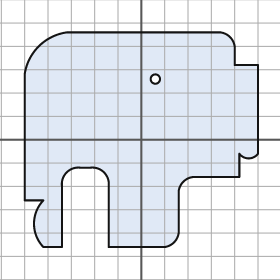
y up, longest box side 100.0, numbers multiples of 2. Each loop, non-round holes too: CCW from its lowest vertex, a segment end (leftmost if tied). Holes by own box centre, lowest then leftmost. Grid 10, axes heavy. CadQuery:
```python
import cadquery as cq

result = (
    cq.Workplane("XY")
    .moveTo(-42.0, -46.0)
    .lineTo(-34.0, -46.0)
    .lineTo(-34.0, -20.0)
    .threePointArc((-32.0, -14.0), (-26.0, -12.0))
    .lineTo(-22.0, -12.0)
    .threePointArc((-16.0, -14.0), (-14.0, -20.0))
    .lineTo(-14.0, -46.0)
    .lineTo(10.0, -46.0)
    .threePointArc((14.0, -44.0), (16.0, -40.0))
    .lineTo(16.0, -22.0)
    .threePointArc((18.0, -18.0), (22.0, -16.0))
    .lineTo(42.0, -16.0)
    .lineTo(42.0, -6.0)
    .threePointArc((46.0, -8.0), (50.0, -6.0))
    .lineTo(50.0, 32.0)
    .lineTo(40.0, 32.0)
    .lineTo(40.0, 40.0)
    .threePointArc((38.0, 44.0), (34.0, 46.0))
    .lineTo(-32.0, 46.0)
    .threePointArc((-44.0, 40.0), (-50.0, 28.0))
    .lineTo(-50.0, -26.0)
    .lineTo(-42.0, -26.0)
    .threePointArc((-46.0, -36.0), (-42.0, -46.0))
    .close()
    .moveTo(6.0, 26.0)
    .circle(2.0)
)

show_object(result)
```